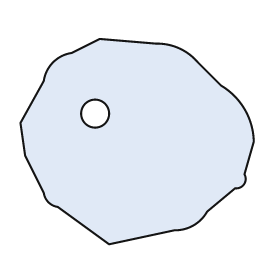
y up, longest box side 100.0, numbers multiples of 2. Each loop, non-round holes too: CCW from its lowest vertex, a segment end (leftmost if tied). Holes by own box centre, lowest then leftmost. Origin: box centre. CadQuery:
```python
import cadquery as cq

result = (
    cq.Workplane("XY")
    .moveTo(-12.0, -44.0)
    .lineTo(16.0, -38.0)
    .threePointArc((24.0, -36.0), (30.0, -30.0))
    .lineTo(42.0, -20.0)
    .threePointArc((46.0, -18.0), (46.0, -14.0))
    .lineTo(50.0, 0.0)
    .threePointArc((46.0, 14.0), (36.0, 24.0))
    .lineTo(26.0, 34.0)
    .threePointArc((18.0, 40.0), (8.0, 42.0))
    .lineTo(-16.0, 44.0)
    .lineTo(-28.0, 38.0)
    .threePointArc((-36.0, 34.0), (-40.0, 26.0))
    .lineTo(-50.0, 8.0)
    .lineTo(-48.0, -6.0)
    .lineTo(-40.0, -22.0)
    .threePointArc((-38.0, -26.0), (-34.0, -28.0))
    .close()
    .moveTo(-18.0, 12.0)
    .circle(6.0)
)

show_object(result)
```